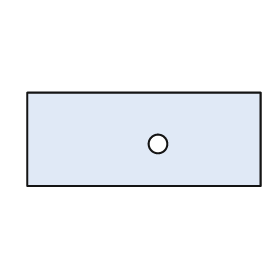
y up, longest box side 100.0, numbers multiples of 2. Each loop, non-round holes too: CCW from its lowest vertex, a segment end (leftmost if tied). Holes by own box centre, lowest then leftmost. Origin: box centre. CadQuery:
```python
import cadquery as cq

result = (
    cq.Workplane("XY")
    .moveTo(-50.0, -20.0)
    .lineTo(50.0, -20.0)
    .lineTo(50.0, 20.0)
    .lineTo(-50.0, 20.0)
    .close()
    .moveTo(6.0, -2.0)
    .circle(4.0)
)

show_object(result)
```